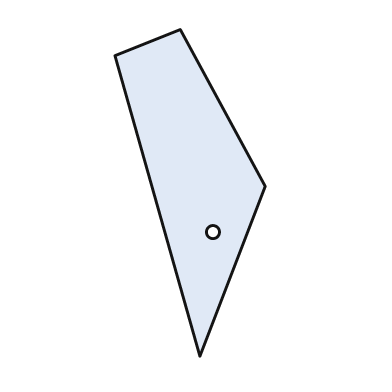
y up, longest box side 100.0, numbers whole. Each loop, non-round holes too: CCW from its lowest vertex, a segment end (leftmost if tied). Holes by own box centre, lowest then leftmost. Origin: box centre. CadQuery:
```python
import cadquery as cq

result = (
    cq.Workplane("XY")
    .moveTo(3.0, -50.0)
    .lineTo(23.0, 2.0)
    .lineTo(-3.0, 50.0)
    .lineTo(-23.0, 42.0)
    .close()
    .moveTo(7.0, -12.0)
    .circle(2.0)
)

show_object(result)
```